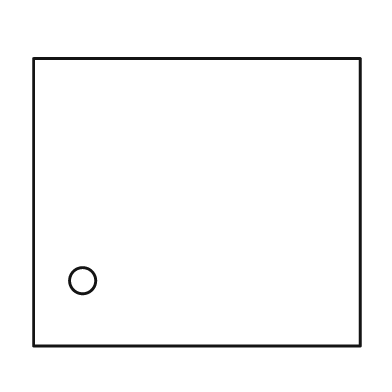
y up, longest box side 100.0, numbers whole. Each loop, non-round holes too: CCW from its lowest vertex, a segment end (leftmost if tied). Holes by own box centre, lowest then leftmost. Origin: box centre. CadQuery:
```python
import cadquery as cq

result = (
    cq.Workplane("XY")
    .moveTo(-50.0, -44.0)
    .lineTo(50.0, -44.0)
    .lineTo(50.0, 44.0)
    .lineTo(-50.0, 44.0)
    .close()
    .moveTo(-35.0, -24.0)
    .circle(4.0)
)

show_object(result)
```